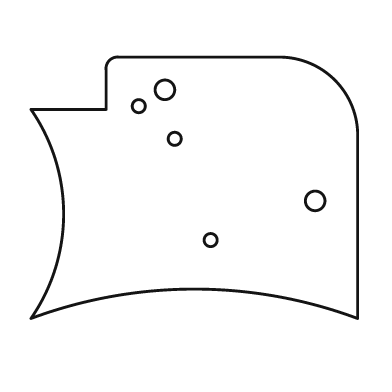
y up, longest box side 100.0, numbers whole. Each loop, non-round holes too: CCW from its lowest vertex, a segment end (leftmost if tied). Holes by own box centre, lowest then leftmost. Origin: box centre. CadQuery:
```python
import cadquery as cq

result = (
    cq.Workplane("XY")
    .moveTo(-50.0, -40.0)
    .threePointArc((0.0, -31.0), (50.0, -40.0))
    .lineTo(50.0, 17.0)
    .threePointArc((43.0, 33.0), (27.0, 40.0))
    .lineTo(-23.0, 40.0)
    .threePointArc((-26.0, 39.0), (-27.0, 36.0))
    .lineTo(-27.0, 24.0)
    .lineTo(-50.0, 24.0)
    .threePointArc((-40.0, -8.0), (-50.0, -40.0))
    .close()
    .moveTo(5.0, -16.0)
    .circle(2.0)
    .moveTo(37.0, -4.0)
    .circle(3.0)
    .moveTo(-6.0, 15.0)
    .circle(2.0)
    .moveTo(-17.0, 25.0)
    .circle(2.0)
    .moveTo(-9.0, 30.0)
    .circle(3.0)
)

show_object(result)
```